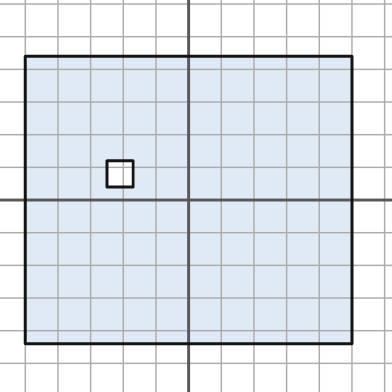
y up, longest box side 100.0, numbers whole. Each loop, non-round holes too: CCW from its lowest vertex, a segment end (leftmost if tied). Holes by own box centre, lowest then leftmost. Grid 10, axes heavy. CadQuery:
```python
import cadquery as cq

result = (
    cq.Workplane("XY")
    .moveTo(-50.0, -44.0)
    .lineTo(50.0, -44.0)
    .lineTo(50.0, 44.0)
    .lineTo(-50.0, 44.0)
    .close()
    .moveTo(-25.0, 4.0)
    .lineTo(-17.0, 4.0)
    .lineTo(-17.0, 12.0)
    .lineTo(-25.0, 12.0)
    .close()
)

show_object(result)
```